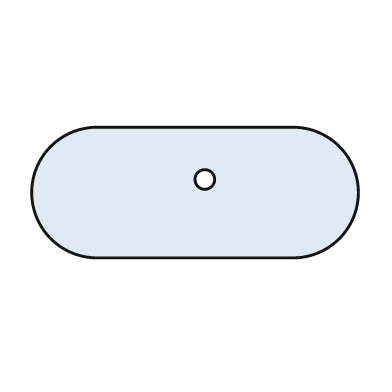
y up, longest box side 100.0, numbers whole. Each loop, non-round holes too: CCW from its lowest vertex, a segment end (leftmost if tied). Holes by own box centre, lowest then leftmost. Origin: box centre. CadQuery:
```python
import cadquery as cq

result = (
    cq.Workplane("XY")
    .moveTo(-30.0, -20.0)
    .lineTo(30.0, -20.0)
    .threePointArc((50.0, 0.0), (30.0, 20.0))
    .lineTo(-30.0, 20.0)
    .threePointArc((-50.0, 0.0), (-30.0, -20.0))
    .close()
    .moveTo(3.0, 4.0)
    .circle(3.0)
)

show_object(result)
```